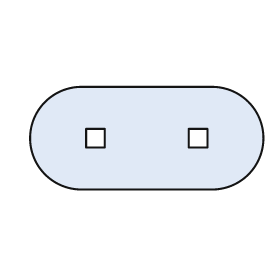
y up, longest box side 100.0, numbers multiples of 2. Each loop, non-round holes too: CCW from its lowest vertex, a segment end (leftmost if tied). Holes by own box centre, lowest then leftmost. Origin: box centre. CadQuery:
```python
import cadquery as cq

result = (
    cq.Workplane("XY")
    .moveTo(-28.0, -22.0)
    .lineTo(28.0, -22.0)
    .threePointArc((50.0, 0.0), (28.0, 22.0))
    .lineTo(-28.0, 22.0)
    .threePointArc((-50.0, 0.0), (-28.0, -22.0))
    .close()
    .moveTo(-26.0, -4.0)
    .lineTo(-18.0, -4.0)
    .lineTo(-18.0, 4.0)
    .lineTo(-26.0, 4.0)
    .close()
    .moveTo(18.0, -4.0)
    .lineTo(26.0, -4.0)
    .lineTo(26.0, 4.0)
    .lineTo(18.0, 4.0)
    .close()
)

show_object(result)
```